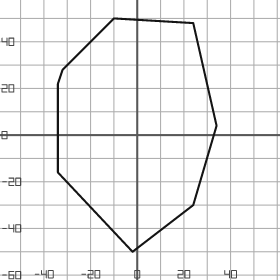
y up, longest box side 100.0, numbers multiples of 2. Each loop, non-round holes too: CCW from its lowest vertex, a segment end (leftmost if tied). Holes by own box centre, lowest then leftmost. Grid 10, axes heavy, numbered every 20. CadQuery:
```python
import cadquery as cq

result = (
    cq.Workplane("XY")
    .moveTo(-2.0, -50.0)
    .lineTo(24.0, -30.0)
    .lineTo(34.0, 4.0)
    .lineTo(24.0, 48.0)
    .lineTo(-10.0, 50.0)
    .lineTo(-32.0, 28.0)
    .lineTo(-34.0, 22.0)
    .lineTo(-34.0, -16.0)
    .close()
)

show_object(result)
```